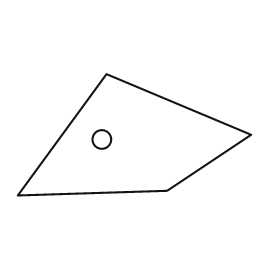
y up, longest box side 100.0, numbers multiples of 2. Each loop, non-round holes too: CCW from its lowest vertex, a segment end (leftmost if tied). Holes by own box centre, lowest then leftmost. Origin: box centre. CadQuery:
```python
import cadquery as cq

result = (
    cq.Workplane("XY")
    .moveTo(-50.0, -26.0)
    .lineTo(14.0, -24.0)
    .lineTo(50.0, 0.0)
    .lineTo(-12.0, 26.0)
    .close()
    .moveTo(-14.0, -2.0)
    .circle(4.0)
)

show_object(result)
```